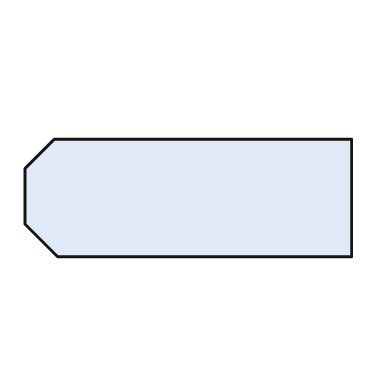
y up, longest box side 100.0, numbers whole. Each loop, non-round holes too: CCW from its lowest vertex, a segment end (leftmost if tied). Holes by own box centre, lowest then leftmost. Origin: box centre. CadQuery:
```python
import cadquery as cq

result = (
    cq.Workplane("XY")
    .moveTo(-40.0, -18.0)
    .lineTo(50.0, -18.0)
    .lineTo(50.0, 18.0)
    .lineTo(-41.0, 18.0)
    .lineTo(-50.0, 9.0)
    .lineTo(-50.0, -8.0)
    .close()
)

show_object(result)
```